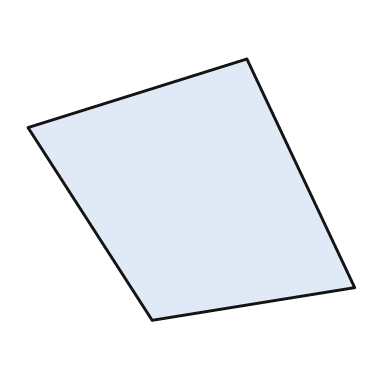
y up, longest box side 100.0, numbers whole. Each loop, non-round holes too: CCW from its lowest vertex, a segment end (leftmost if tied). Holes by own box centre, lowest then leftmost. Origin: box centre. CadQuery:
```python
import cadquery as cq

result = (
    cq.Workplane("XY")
    .moveTo(-12.0, -40.0)
    .lineTo(50.0, -30.0)
    .lineTo(17.0, 40.0)
    .lineTo(-50.0, 19.0)
    .close()
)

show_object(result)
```